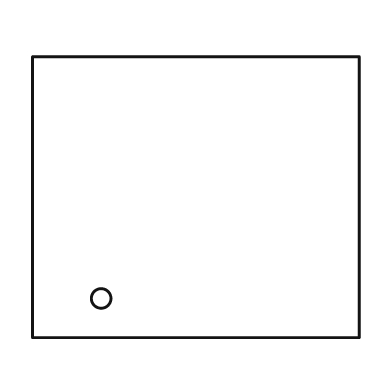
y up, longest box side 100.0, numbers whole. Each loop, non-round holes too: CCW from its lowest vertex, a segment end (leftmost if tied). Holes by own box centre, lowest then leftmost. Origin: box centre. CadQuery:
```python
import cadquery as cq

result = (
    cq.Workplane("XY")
    .moveTo(-50.0, -43.0)
    .lineTo(50.0, -43.0)
    .lineTo(50.0, 43.0)
    .lineTo(-50.0, 43.0)
    .close()
    .moveTo(-29.0, -31.0)
    .circle(3.0)
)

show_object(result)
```